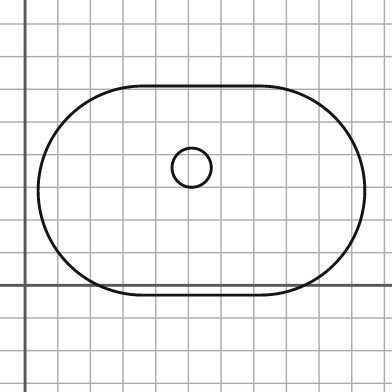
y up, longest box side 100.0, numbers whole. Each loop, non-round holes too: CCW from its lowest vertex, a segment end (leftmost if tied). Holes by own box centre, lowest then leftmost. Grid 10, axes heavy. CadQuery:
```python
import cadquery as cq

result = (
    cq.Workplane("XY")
    .moveTo(36.0, -3.0)
    .lineTo(72.0, -3.0)
    .threePointArc((104.0, 29.0), (72.0, 61.0))
    .lineTo(36.0, 61.0)
    .threePointArc((4.0, 29.0), (36.0, -3.0))
    .close()
    .moveTo(51.0, 36.0)
    .circle(6.0)
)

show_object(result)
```